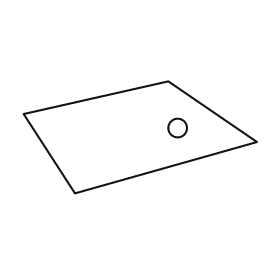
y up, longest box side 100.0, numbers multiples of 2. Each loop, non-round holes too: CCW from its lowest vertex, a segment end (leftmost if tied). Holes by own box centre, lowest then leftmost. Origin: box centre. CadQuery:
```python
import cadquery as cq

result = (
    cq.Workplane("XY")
    .moveTo(-28.0, -24.0)
    .lineTo(50.0, -2.0)
    .lineTo(12.0, 24.0)
    .lineTo(-50.0, 10.0)
    .close()
    .moveTo(16.0, 4.0)
    .circle(4.0)
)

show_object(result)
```